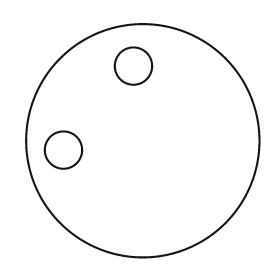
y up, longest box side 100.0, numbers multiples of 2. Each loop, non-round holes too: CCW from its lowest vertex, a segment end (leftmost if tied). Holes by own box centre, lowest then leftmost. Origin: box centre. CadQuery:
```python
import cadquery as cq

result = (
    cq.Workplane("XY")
    .moveTo(0.0, 0.0)
    .circle(50.0)
    .moveTo(-34.0, -4.0)
    .circle(8.0)
    .moveTo(-4.0, 32.0)
    .circle(8.0)
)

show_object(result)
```